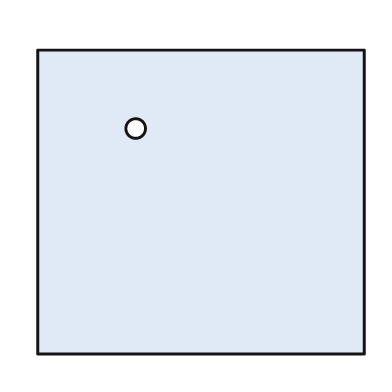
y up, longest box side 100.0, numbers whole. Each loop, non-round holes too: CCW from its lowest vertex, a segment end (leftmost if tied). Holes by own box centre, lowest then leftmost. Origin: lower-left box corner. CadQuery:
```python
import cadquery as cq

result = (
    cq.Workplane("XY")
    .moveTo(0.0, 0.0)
    .lineTo(100.0, 0.0)
    .lineTo(100.0, 93.0)
    .lineTo(0.0, 93.0)
    .close()
    .moveTo(30.0, 69.0)
    .circle(3.0)
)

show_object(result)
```